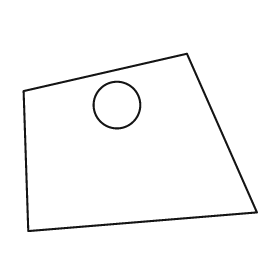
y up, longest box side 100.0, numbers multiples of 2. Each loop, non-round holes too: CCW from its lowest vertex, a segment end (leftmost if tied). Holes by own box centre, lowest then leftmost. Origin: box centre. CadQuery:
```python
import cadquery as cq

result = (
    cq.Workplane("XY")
    .moveTo(-48.0, -38.0)
    .lineTo(50.0, -30.0)
    .lineTo(20.0, 38.0)
    .lineTo(-50.0, 22.0)
    .close()
    .moveTo(-10.0, 16.0)
    .circle(10.0)
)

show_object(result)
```